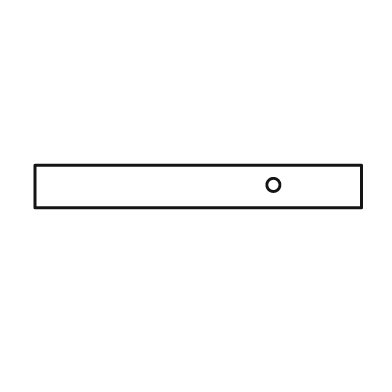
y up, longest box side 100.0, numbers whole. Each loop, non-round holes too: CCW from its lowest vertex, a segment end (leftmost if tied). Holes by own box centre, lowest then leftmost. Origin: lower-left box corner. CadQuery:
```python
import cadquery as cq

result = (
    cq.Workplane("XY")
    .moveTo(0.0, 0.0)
    .lineTo(100.0, 0.0)
    .lineTo(100.0, 13.0)
    .lineTo(0.0, 13.0)
    .close()
    .moveTo(73.0, 7.0)
    .circle(2.0)
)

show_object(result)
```